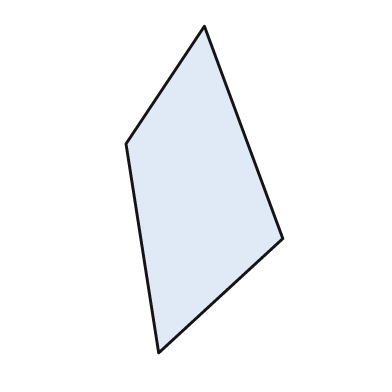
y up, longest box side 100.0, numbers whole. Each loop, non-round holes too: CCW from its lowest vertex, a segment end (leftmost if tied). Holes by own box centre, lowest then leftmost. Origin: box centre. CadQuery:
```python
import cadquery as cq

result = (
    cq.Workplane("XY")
    .moveTo(-14.0, -50.0)
    .lineTo(24.0, -15.0)
    .lineTo(0.0, 50.0)
    .lineTo(-24.0, 14.0)
    .close()
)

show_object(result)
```